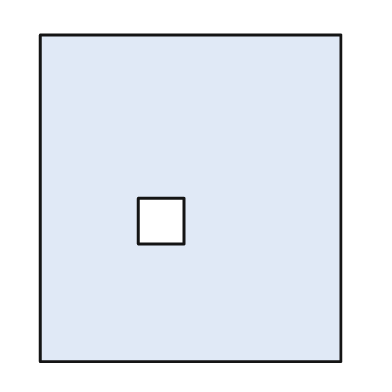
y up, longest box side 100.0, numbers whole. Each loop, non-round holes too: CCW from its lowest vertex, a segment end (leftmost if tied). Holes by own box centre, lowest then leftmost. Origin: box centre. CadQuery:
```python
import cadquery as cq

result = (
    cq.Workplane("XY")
    .moveTo(-46.0, -50.0)
    .lineTo(46.0, -50.0)
    .lineTo(46.0, 50.0)
    .lineTo(-46.0, 50.0)
    .close()
    .moveTo(-16.0, -14.0)
    .lineTo(-2.0, -14.0)
    .lineTo(-2.0, 0.0)
    .lineTo(-16.0, 0.0)
    .close()
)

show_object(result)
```